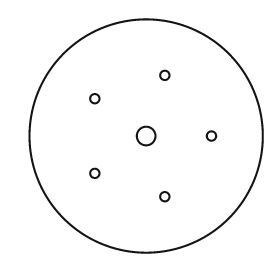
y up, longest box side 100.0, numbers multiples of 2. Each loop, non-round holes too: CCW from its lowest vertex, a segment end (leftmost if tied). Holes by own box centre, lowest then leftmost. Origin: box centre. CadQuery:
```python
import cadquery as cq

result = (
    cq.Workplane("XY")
    .moveTo(0.0, 0.0)
    .circle(50.0)
    .moveTo(8.0, -26.0)
    .circle(2.0)
    .moveTo(-22.0, -16.0)
    .circle(2.0)
    .moveTo(0.0, 0.0)
    .circle(4.0)
    .moveTo(28.0, 0.0)
    .circle(2.0)
    .moveTo(-22.0, 16.0)
    .circle(2.0)
    .moveTo(8.0, 26.0)
    .circle(2.0)
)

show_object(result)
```